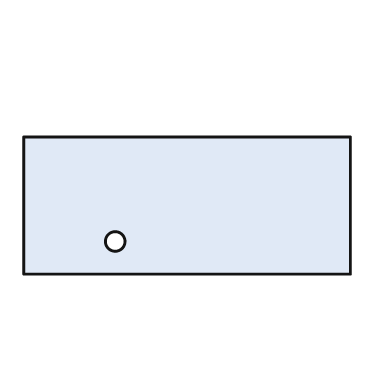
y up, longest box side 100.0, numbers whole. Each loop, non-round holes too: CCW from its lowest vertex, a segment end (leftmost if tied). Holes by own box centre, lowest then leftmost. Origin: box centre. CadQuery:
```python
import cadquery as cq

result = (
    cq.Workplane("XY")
    .moveTo(-50.0, -21.0)
    .lineTo(50.0, -21.0)
    .lineTo(50.0, 21.0)
    .lineTo(-50.0, 21.0)
    .close()
    .moveTo(-22.0, -11.0)
    .circle(3.0)
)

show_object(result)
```